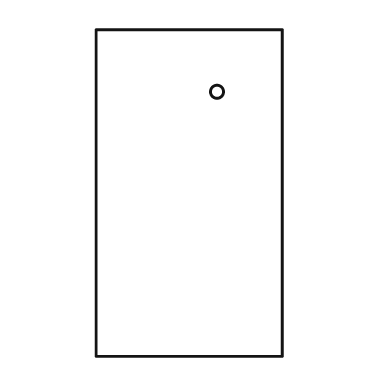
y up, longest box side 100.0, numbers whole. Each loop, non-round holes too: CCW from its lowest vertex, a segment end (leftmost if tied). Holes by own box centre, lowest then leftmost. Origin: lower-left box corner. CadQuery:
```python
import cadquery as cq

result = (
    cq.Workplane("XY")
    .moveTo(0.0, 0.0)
    .lineTo(57.0, 0.0)
    .lineTo(57.0, 100.0)
    .lineTo(0.0, 100.0)
    .close()
    .moveTo(37.0, 81.0)
    .circle(2.0)
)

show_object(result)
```